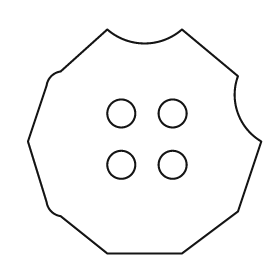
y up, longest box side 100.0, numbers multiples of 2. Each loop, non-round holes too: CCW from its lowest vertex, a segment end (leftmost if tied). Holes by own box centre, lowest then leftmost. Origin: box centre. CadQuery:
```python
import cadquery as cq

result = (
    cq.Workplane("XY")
    .moveTo(-16.0, -48.0)
    .lineTo(16.0, -48.0)
    .lineTo(40.0, -30.0)
    .lineTo(50.0, 0.0)
    .threePointArc((40.0, 12.0), (40.0, 28.0))
    .lineTo(16.0, 48.0)
    .threePointArc((0.0, 42.0), (-16.0, 48.0))
    .lineTo(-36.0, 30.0)
    .threePointArc((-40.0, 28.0), (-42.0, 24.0))
    .lineTo(-50.0, 0.0)
    .lineTo(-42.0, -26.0)
    .threePointArc((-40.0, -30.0), (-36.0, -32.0))
    .close()
    .moveTo(-10.0, -10.0)
    .circle(6.0)
    .moveTo(12.0, -10.0)
    .circle(6.0)
    .moveTo(-10.0, 12.0)
    .circle(6.0)
    .moveTo(12.0, 12.0)
    .circle(6.0)
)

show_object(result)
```